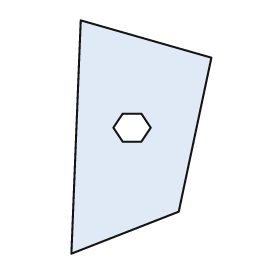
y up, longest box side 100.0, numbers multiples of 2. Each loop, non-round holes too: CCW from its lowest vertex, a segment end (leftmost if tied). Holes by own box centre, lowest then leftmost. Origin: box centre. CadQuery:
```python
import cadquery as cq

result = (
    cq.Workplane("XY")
    .moveTo(-30.0, -50.0)
    .lineTo(16.0, -32.0)
    .lineTo(30.0, 34.0)
    .lineTo(-26.0, 50.0)
    .close()
    .moveTo(-8.0, -2.0)
    .lineTo(0.0, -2.0)
    .lineTo(4.0, 4.0)
    .lineTo(0.0, 10.0)
    .lineTo(-8.0, 10.0)
    .lineTo(-12.0, 4.0)
    .close()
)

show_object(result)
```